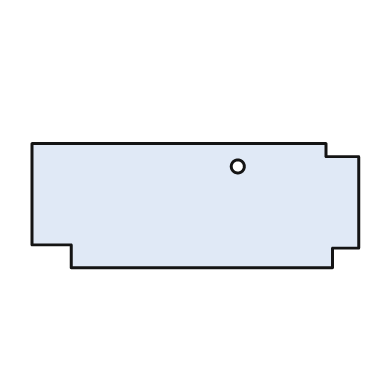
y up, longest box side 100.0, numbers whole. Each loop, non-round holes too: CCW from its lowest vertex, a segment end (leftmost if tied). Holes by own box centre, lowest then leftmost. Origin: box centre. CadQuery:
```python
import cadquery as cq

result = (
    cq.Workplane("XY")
    .moveTo(-38.0, -19.0)
    .lineTo(42.0, -19.0)
    .lineTo(42.0, -13.0)
    .lineTo(50.0, -13.0)
    .lineTo(50.0, 15.0)
    .lineTo(40.0, 15.0)
    .lineTo(40.0, 19.0)
    .lineTo(-50.0, 19.0)
    .lineTo(-50.0, -12.0)
    .lineTo(-38.0, -12.0)
    .close()
    .moveTo(13.0, 12.0)
    .circle(2.0)
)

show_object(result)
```